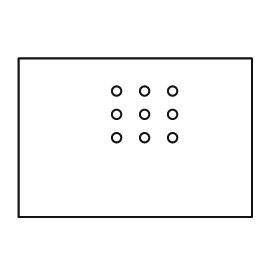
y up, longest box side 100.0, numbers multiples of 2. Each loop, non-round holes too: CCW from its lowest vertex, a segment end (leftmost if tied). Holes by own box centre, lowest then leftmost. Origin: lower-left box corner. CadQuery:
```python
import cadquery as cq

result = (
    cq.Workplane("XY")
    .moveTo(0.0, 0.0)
    .lineTo(100.0, 0.0)
    .lineTo(100.0, 68.0)
    .lineTo(0.0, 68.0)
    .close()
    .moveTo(42.0, 34.0)
    .circle(2.0)
    .moveTo(54.0, 34.0)
    .circle(2.0)
    .moveTo(66.0, 34.0)
    .circle(2.0)
    .moveTo(42.0, 44.0)
    .circle(2.0)
    .moveTo(54.0, 44.0)
    .circle(2.0)
    .moveTo(66.0, 44.0)
    .circle(2.0)
    .moveTo(42.0, 54.0)
    .circle(2.0)
    .moveTo(54.0, 54.0)
    .circle(2.0)
    .moveTo(66.0, 54.0)
    .circle(2.0)
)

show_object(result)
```